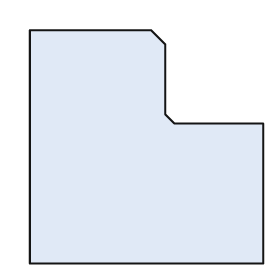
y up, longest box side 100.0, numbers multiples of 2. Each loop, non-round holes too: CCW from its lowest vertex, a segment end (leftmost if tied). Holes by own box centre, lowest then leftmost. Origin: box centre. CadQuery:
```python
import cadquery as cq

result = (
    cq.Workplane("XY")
    .moveTo(-50.0, -50.0)
    .lineTo(50.0, -50.0)
    .lineTo(50.0, 10.0)
    .lineTo(12.0, 10.0)
    .lineTo(8.0, 14.0)
    .lineTo(8.0, 44.0)
    .lineTo(2.0, 50.0)
    .lineTo(-50.0, 50.0)
    .close()
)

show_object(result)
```